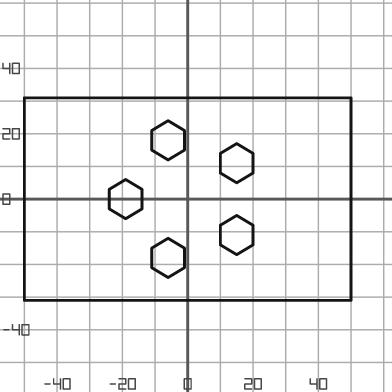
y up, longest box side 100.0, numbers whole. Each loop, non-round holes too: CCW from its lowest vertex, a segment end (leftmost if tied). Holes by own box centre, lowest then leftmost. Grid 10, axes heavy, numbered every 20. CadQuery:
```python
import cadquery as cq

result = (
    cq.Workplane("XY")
    .moveTo(-50.0, -31.0)
    .lineTo(50.0, -31.0)
    .lineTo(50.0, 31.0)
    .lineTo(-50.0, 31.0)
    .close()
    .moveTo(-6.0, -24.0)
    .lineTo(-1.0, -21.0)
    .lineTo(-1.0, -15.0)
    .lineTo(-6.0, -12.0)
    .lineTo(-11.0, -15.0)
    .lineTo(-11.0, -21.0)
    .close()
    .moveTo(15.0, -17.0)
    .lineTo(20.0, -14.0)
    .lineTo(20.0, -8.0)
    .lineTo(15.0, -5.0)
    .lineTo(10.0, -8.0)
    .lineTo(10.0, -14.0)
    .close()
    .moveTo(-19.0, -6.0)
    .lineTo(-14.0, -3.0)
    .lineTo(-14.0, 3.0)
    .lineTo(-19.0, 6.0)
    .lineTo(-24.0, 3.0)
    .lineTo(-24.0, -3.0)
    .close()
    .moveTo(15.0, 5.0)
    .lineTo(20.0, 8.0)
    .lineTo(20.0, 14.0)
    .lineTo(15.0, 17.0)
    .lineTo(10.0, 14.0)
    .lineTo(10.0, 8.0)
    .close()
    .moveTo(-6.0, 12.0)
    .lineTo(-1.0, 15.0)
    .lineTo(-1.0, 21.0)
    .lineTo(-6.0, 24.0)
    .lineTo(-11.0, 21.0)
    .lineTo(-11.0, 15.0)
    .close()
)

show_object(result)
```